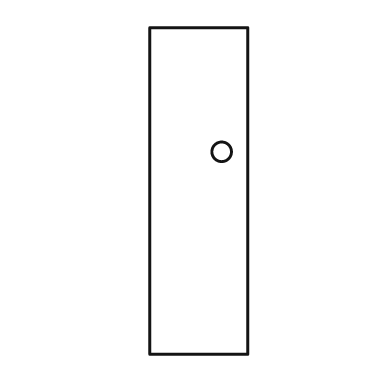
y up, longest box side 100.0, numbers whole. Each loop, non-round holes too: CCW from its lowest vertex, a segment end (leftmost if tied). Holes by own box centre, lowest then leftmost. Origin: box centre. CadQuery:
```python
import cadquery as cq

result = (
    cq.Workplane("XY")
    .moveTo(-15.0, -50.0)
    .lineTo(15.0, -50.0)
    .lineTo(15.0, 50.0)
    .lineTo(-15.0, 50.0)
    .close()
    .moveTo(7.0, 12.0)
    .circle(3.0)
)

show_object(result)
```